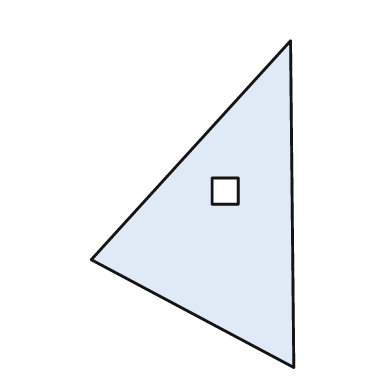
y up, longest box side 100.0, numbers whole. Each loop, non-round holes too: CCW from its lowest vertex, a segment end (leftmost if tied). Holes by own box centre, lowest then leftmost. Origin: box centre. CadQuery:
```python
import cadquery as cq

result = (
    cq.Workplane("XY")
    .moveTo(31.0, -50.0)
    .lineTo(30.0, 50.0)
    .lineTo(-31.0, -17.0)
    .close()
    .moveTo(6.0, 0.0)
    .lineTo(14.0, 0.0)
    .lineTo(14.0, 8.0)
    .lineTo(6.0, 8.0)
    .close()
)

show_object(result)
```